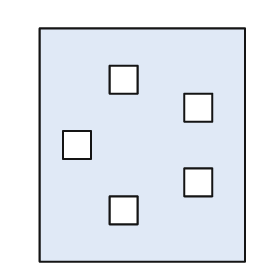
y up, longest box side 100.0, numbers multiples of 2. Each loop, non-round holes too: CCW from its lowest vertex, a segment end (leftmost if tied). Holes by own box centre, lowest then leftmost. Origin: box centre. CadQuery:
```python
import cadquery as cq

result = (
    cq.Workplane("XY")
    .moveTo(-44.0, -50.0)
    .lineTo(44.0, -50.0)
    .lineTo(44.0, 50.0)
    .lineTo(-44.0, 50.0)
    .close()
    .moveTo(-14.0, -34.0)
    .lineTo(-2.0, -34.0)
    .lineTo(-2.0, -22.0)
    .lineTo(-14.0, -22.0)
    .close()
    .moveTo(18.0, -22.0)
    .lineTo(30.0, -22.0)
    .lineTo(30.0, -10.0)
    .lineTo(18.0, -10.0)
    .close()
    .moveTo(-34.0, -6.0)
    .lineTo(-22.0, -6.0)
    .lineTo(-22.0, 6.0)
    .lineTo(-34.0, 6.0)
    .close()
    .moveTo(18.0, 10.0)
    .lineTo(30.0, 10.0)
    .lineTo(30.0, 22.0)
    .lineTo(18.0, 22.0)
    .close()
    .moveTo(-14.0, 22.0)
    .lineTo(-2.0, 22.0)
    .lineTo(-2.0, 34.0)
    .lineTo(-14.0, 34.0)
    .close()
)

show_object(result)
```